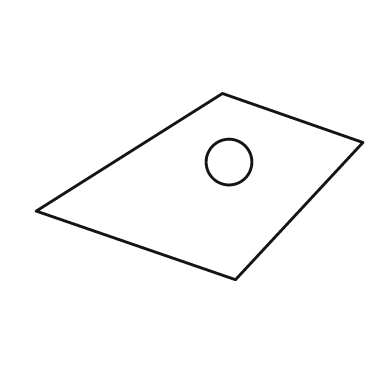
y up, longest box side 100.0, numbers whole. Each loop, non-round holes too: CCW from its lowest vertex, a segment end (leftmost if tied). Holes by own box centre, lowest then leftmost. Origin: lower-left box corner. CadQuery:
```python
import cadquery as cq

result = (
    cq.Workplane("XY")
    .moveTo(61.0, 0.0)
    .lineTo(100.0, 42.0)
    .lineTo(57.0, 57.0)
    .lineTo(0.0, 21.0)
    .close()
    .moveTo(59.0, 36.0)
    .circle(7.0)
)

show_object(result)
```